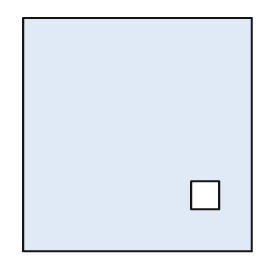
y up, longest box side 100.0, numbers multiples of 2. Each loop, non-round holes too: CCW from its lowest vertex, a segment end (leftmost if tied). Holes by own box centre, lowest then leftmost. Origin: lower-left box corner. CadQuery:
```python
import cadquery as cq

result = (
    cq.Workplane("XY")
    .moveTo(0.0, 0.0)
    .lineTo(98.0, 0.0)
    .lineTo(98.0, 100.0)
    .lineTo(0.0, 100.0)
    .close()
    .moveTo(72.0, 18.0)
    .lineTo(84.0, 18.0)
    .lineTo(84.0, 30.0)
    .lineTo(72.0, 30.0)
    .close()
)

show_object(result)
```